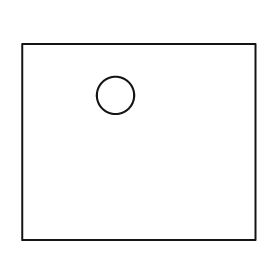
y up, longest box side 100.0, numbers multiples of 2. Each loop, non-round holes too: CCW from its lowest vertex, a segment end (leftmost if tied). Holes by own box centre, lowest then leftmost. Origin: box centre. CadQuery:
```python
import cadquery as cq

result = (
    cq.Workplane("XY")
    .moveTo(-50.0, -42.0)
    .lineTo(50.0, -42.0)
    .lineTo(50.0, 42.0)
    .lineTo(-50.0, 42.0)
    .close()
    .moveTo(-10.0, 20.0)
    .circle(8.0)
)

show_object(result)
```